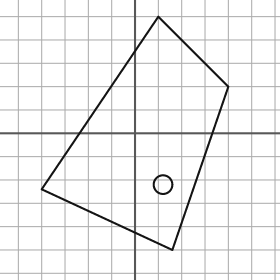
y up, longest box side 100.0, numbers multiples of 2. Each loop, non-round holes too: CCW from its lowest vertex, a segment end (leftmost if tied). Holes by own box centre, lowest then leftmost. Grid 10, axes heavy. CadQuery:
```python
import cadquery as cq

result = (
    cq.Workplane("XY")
    .moveTo(16.0, -50.0)
    .lineTo(40.0, 20.0)
    .lineTo(10.0, 50.0)
    .lineTo(-40.0, -24.0)
    .close()
    .moveTo(12.0, -22.0)
    .circle(4.0)
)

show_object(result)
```